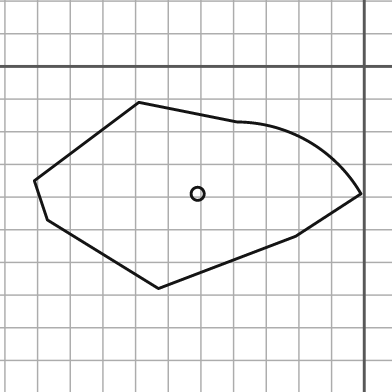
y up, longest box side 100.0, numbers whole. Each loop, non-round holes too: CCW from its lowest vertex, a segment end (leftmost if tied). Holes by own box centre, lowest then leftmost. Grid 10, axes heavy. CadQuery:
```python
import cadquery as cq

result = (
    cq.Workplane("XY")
    .moveTo(-63.0, -68.0)
    .lineTo(-21.0, -52.0)
    .lineTo(-1.0, -39.0)
    .threePointArc((-17.0, -23.0), (-39.0, -17.0))
    .lineTo(-69.0, -11.0)
    .lineTo(-101.0, -35.0)
    .lineTo(-97.0, -47.0)
    .close()
    .moveTo(-51.0, -39.0)
    .circle(2.0)
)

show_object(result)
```